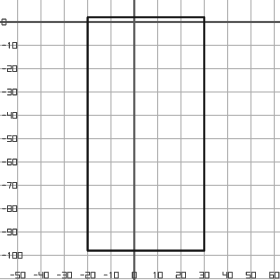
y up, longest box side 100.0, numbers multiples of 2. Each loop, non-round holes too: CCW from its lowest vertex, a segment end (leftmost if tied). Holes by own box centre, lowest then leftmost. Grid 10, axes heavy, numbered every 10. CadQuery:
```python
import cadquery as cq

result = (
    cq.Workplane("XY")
    .moveTo(-20.0, -98.0)
    .lineTo(30.0, -98.0)
    .lineTo(30.0, 2.0)
    .lineTo(-20.0, 2.0)
    .close()
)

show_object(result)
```